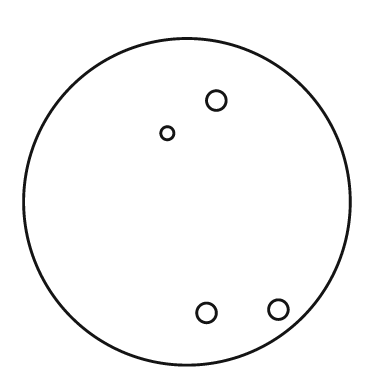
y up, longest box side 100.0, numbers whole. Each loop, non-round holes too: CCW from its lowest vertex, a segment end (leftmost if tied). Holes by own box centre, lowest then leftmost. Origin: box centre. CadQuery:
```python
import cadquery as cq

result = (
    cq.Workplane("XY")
    .moveTo(0.0, 0.0)
    .circle(50.0)
    .moveTo(6.0, -34.0)
    .circle(3.0)
    .moveTo(28.0, -33.0)
    .circle(3.0)
    .moveTo(-6.0, 21.0)
    .circle(2.0)
    .moveTo(9.0, 31.0)
    .circle(3.0)
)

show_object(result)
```